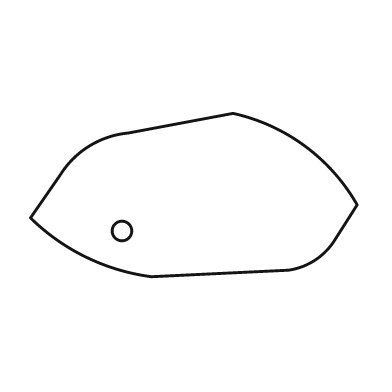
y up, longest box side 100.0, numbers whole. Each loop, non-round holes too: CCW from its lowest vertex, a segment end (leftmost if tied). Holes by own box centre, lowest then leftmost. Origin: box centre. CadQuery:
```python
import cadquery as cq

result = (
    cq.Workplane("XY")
    .moveTo(-13.0, -25.0)
    .lineTo(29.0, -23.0)
    .threePointArc((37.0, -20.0), (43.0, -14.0))
    .lineTo(50.0, -3.0)
    .threePointArc((34.0, 15.0), (12.0, 25.0))
    .lineTo(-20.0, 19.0)
    .threePointArc((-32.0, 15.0), (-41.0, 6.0))
    .lineTo(-50.0, -7.0)
    .threePointArc((-33.0, -19.0), (-13.0, -25.0))
    .close()
    .moveTo(-22.0, -11.0)
    .circle(3.0)
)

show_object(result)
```